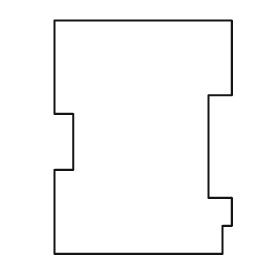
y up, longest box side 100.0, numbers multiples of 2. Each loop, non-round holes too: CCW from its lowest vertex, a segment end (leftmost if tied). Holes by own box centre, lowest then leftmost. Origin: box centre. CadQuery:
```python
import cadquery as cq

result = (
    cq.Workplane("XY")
    .moveTo(-38.0, -50.0)
    .lineTo(34.0, -50.0)
    .lineTo(34.0, -38.0)
    .lineTo(38.0, -38.0)
    .lineTo(38.0, -26.0)
    .lineTo(28.0, -26.0)
    .lineTo(28.0, 18.0)
    .lineTo(38.0, 18.0)
    .lineTo(38.0, 50.0)
    .lineTo(-38.0, 50.0)
    .lineTo(-38.0, 10.0)
    .lineTo(-30.0, 10.0)
    .lineTo(-30.0, -14.0)
    .lineTo(-38.0, -14.0)
    .close()
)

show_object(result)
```